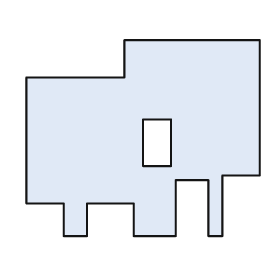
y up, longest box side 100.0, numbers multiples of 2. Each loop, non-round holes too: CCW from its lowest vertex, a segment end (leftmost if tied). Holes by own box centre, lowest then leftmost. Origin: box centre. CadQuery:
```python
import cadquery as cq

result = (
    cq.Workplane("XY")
    .moveTo(-34.0, -42.0)
    .lineTo(-24.0, -42.0)
    .lineTo(-24.0, -28.0)
    .lineTo(-4.0, -28.0)
    .lineTo(-4.0, -42.0)
    .lineTo(14.0, -42.0)
    .lineTo(14.0, -18.0)
    .lineTo(28.0, -18.0)
    .lineTo(28.0, -42.0)
    .lineTo(34.0, -42.0)
    .lineTo(34.0, -16.0)
    .lineTo(50.0, -16.0)
    .lineTo(50.0, 42.0)
    .lineTo(-8.0, 42.0)
    .lineTo(-8.0, 26.0)
    .lineTo(-50.0, 26.0)
    .lineTo(-50.0, -28.0)
    .lineTo(-34.0, -28.0)
    .close()
    .moveTo(0.0, -12.0)
    .lineTo(12.0, -12.0)
    .lineTo(12.0, 8.0)
    .lineTo(0.0, 8.0)
    .close()
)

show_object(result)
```